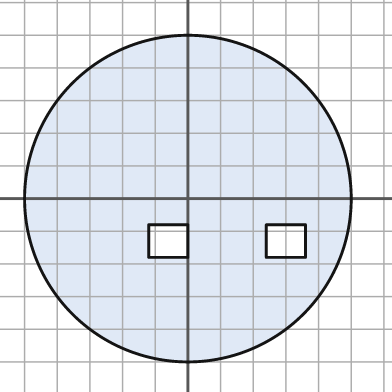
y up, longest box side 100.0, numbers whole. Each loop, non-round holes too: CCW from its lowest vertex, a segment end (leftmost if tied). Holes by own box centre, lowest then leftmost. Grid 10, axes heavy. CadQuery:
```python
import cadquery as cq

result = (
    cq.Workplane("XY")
    .moveTo(0.0, 0.0)
    .circle(50.0)
    .moveTo(-12.0, -18.0)
    .lineTo(0.0, -18.0)
    .lineTo(0.0, -8.0)
    .lineTo(-12.0, -8.0)
    .close()
    .moveTo(24.0, -18.0)
    .lineTo(36.0, -18.0)
    .lineTo(36.0, -8.0)
    .lineTo(24.0, -8.0)
    .close()
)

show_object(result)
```